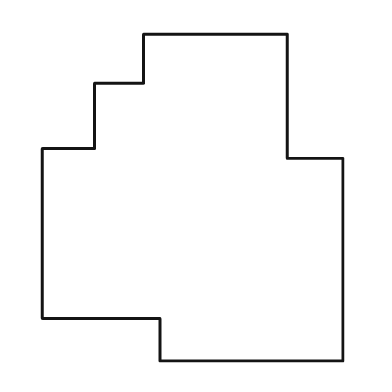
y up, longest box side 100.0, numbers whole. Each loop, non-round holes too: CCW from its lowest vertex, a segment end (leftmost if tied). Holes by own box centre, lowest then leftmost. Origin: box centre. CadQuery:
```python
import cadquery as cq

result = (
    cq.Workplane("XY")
    .moveTo(-10.0, -50.0)
    .lineTo(46.0, -50.0)
    .lineTo(46.0, 12.0)
    .lineTo(29.0, 12.0)
    .lineTo(29.0, 50.0)
    .lineTo(-15.0, 50.0)
    .lineTo(-15.0, 35.0)
    .lineTo(-30.0, 35.0)
    .lineTo(-30.0, 15.0)
    .lineTo(-46.0, 15.0)
    .lineTo(-46.0, -37.0)
    .lineTo(-10.0, -37.0)
    .close()
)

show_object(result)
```